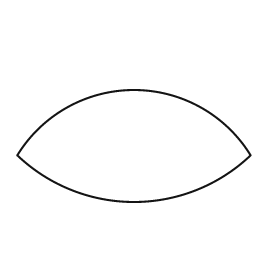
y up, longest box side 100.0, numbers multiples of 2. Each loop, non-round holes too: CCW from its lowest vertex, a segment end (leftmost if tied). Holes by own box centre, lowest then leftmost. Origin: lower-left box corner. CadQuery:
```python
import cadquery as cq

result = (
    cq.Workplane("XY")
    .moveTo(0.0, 20.0)
    .threePointArc((50.0, 0.0), (100.0, 20.0))
    .threePointArc((50.0, 48.0), (0.0, 20.0))
    .close()
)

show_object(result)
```